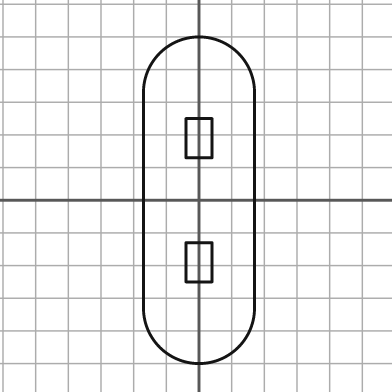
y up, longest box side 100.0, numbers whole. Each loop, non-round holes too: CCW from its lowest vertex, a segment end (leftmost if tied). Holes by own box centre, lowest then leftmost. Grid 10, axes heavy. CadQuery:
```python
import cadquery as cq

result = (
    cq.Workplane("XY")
    .moveTo(-17.0, -33.0)
    .threePointArc((0.0, -50.0), (17.0, -33.0))
    .lineTo(17.0, 33.0)
    .threePointArc((0.0, 50.0), (-17.0, 33.0))
    .close()
    .moveTo(-4.0, -25.0)
    .lineTo(4.0, -25.0)
    .lineTo(4.0, -13.0)
    .lineTo(-4.0, -13.0)
    .close()
    .moveTo(-4.0, 13.0)
    .lineTo(4.0, 13.0)
    .lineTo(4.0, 25.0)
    .lineTo(-4.0, 25.0)
    .close()
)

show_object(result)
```